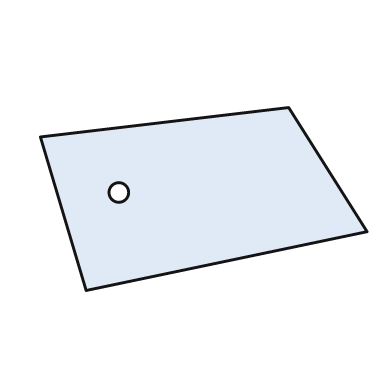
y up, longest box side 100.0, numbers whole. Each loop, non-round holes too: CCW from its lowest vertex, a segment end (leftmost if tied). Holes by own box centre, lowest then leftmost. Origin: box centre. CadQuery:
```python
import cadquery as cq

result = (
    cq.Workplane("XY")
    .moveTo(-36.0, -28.0)
    .lineTo(50.0, -10.0)
    .lineTo(26.0, 28.0)
    .lineTo(-50.0, 19.0)
    .close()
    .moveTo(-26.0, 2.0)
    .circle(3.0)
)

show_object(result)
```